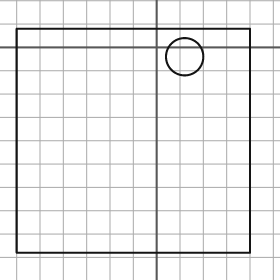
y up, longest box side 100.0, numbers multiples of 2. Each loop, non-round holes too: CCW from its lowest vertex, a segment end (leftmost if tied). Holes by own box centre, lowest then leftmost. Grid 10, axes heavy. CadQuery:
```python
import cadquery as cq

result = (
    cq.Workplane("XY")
    .moveTo(-60.0, -88.0)
    .lineTo(40.0, -88.0)
    .lineTo(40.0, 8.0)
    .lineTo(-60.0, 8.0)
    .close()
    .moveTo(12.0, -4.0)
    .circle(8.0)
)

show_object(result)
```